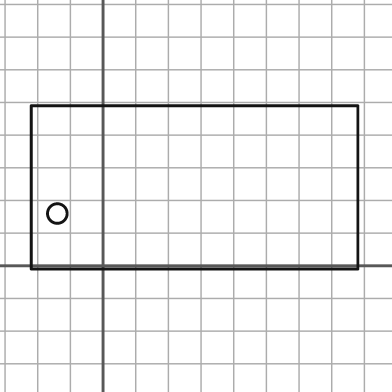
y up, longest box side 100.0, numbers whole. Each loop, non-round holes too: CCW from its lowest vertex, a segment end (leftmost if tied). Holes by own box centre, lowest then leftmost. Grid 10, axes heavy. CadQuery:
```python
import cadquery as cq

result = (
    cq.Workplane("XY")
    .moveTo(-22.0, -1.0)
    .lineTo(78.0, -1.0)
    .lineTo(78.0, 49.0)
    .lineTo(-22.0, 49.0)
    .close()
    .moveTo(-14.0, 16.0)
    .circle(3.0)
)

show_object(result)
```